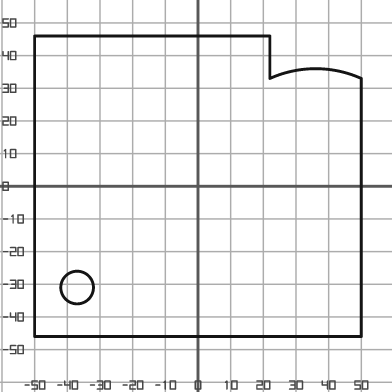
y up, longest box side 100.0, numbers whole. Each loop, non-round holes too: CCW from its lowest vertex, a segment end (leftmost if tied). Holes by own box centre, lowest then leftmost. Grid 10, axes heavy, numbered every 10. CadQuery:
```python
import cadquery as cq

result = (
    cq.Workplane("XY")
    .moveTo(-50.0, -46.0)
    .lineTo(50.0, -46.0)
    .lineTo(50.0, 33.0)
    .threePointArc((36.0, 36.0), (22.0, 33.0))
    .lineTo(22.0, 46.0)
    .lineTo(-50.0, 46.0)
    .close()
    .moveTo(-37.0, -31.0)
    .circle(5.0)
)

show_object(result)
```